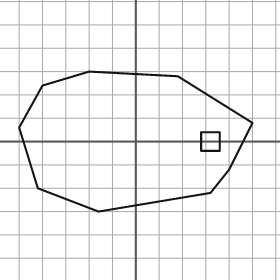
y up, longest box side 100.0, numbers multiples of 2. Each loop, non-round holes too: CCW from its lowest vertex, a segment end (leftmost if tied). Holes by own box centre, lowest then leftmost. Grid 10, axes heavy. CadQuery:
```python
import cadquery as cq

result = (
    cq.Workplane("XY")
    .moveTo(-16.0, -30.0)
    .lineTo(32.0, -22.0)
    .lineTo(40.0, -12.0)
    .lineTo(50.0, 8.0)
    .lineTo(18.0, 28.0)
    .lineTo(-20.0, 30.0)
    .lineTo(-40.0, 24.0)
    .lineTo(-50.0, 6.0)
    .lineTo(-42.0, -20.0)
    .close()
    .moveTo(28.0, -4.0)
    .lineTo(36.0, -4.0)
    .lineTo(36.0, 4.0)
    .lineTo(28.0, 4.0)
    .close()
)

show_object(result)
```